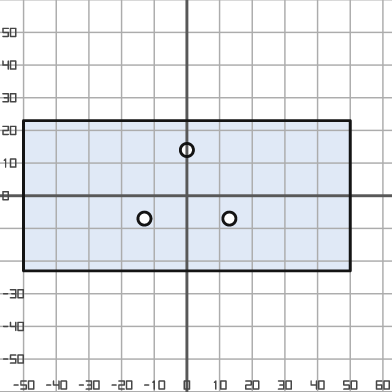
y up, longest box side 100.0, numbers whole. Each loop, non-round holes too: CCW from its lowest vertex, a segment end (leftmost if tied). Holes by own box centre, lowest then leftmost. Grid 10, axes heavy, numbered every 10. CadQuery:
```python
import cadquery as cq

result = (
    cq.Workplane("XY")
    .moveTo(-50.0, -23.0)
    .lineTo(50.0, -23.0)
    .lineTo(50.0, 23.0)
    .lineTo(-50.0, 23.0)
    .close()
    .moveTo(-13.0, -7.0)
    .circle(2.0)
    .moveTo(13.0, -7.0)
    .circle(2.0)
    .moveTo(0.0, 14.0)
    .circle(2.0)
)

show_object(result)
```